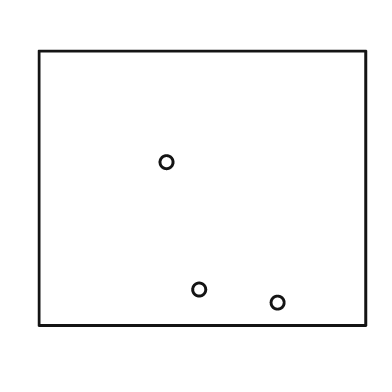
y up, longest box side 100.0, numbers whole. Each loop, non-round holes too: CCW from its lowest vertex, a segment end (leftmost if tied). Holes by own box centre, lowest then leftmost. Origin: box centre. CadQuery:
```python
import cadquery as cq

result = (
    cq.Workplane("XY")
    .moveTo(-50.0, -42.0)
    .lineTo(50.0, -42.0)
    .lineTo(50.0, 42.0)
    .lineTo(-50.0, 42.0)
    .close()
    .moveTo(23.0, -35.0)
    .circle(2.0)
    .moveTo(-1.0, -31.0)
    .circle(2.0)
    .moveTo(-11.0, 8.0)
    .circle(2.0)
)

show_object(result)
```